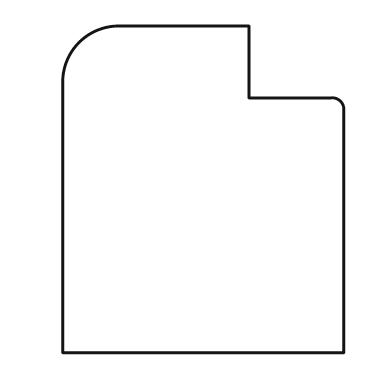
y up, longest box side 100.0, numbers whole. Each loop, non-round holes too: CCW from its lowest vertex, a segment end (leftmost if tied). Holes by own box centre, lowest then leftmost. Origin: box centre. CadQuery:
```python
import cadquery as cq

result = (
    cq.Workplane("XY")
    .moveTo(-43.0, -50.0)
    .lineTo(43.0, -50.0)
    .lineTo(43.0, 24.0)
    .threePointArc((42.0, 27.0), (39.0, 28.0))
    .lineTo(14.0, 28.0)
    .lineTo(14.0, 50.0)
    .lineTo(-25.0, 50.0)
    .threePointArc((-38.0, 45.0), (-43.0, 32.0))
    .close()
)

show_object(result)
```